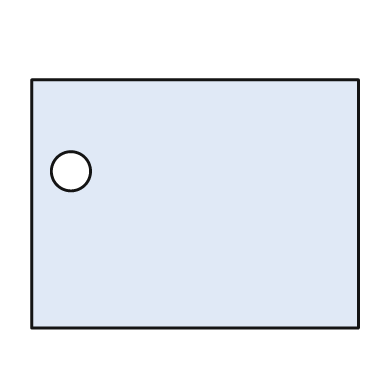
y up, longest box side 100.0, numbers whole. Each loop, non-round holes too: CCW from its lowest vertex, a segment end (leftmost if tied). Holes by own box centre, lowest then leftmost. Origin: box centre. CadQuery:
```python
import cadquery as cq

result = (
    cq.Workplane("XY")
    .moveTo(-50.0, -38.0)
    .lineTo(50.0, -38.0)
    .lineTo(50.0, 38.0)
    .lineTo(-50.0, 38.0)
    .close()
    .moveTo(-38.0, 10.0)
    .circle(6.0)
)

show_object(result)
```